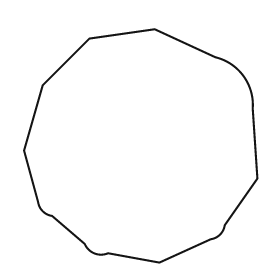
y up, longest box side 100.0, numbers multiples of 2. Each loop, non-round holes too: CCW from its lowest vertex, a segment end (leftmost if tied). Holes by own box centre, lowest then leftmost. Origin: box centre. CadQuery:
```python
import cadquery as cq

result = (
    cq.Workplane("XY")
    .moveTo(8.0, -50.0)
    .lineTo(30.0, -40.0)
    .threePointArc((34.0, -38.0), (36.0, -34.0))
    .lineTo(50.0, -14.0)
    .lineTo(48.0, 16.0)
    .threePointArc((44.0, 30.0), (32.0, 38.0))
    .lineTo(6.0, 50.0)
    .lineTo(-22.0, 46.0)
    .lineTo(-42.0, 26.0)
    .lineTo(-50.0, -2.0)
    .lineTo(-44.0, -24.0)
    .threePointArc((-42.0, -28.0), (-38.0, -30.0))
    .lineTo(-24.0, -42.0)
    .threePointArc((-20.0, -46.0), (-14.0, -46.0))
    .close()
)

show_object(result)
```